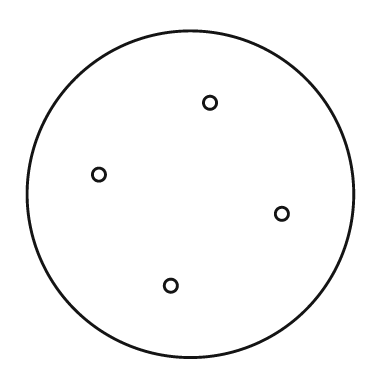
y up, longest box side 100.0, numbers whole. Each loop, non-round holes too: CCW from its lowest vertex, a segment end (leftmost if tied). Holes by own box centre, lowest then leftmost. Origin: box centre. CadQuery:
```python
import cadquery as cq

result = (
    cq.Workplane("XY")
    .moveTo(0.0, 0.0)
    .circle(50.0)
    .moveTo(-6.0, -28.0)
    .circle(2.0)
    .moveTo(28.0, -6.0)
    .circle(2.0)
    .moveTo(-28.0, 6.0)
    .circle(2.0)
    .moveTo(6.0, 28.0)
    .circle(2.0)
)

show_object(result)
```